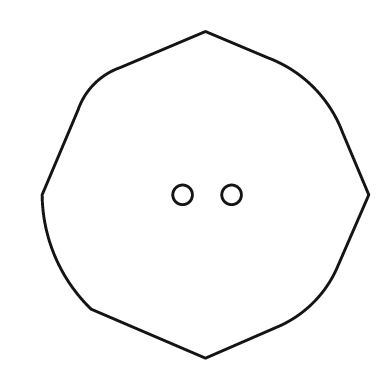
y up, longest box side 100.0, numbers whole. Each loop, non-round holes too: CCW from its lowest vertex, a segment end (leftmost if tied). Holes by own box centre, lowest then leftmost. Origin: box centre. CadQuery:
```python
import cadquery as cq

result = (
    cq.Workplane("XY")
    .moveTo(0.0, -50.0)
    .lineTo(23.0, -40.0)
    .threePointArc((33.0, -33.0), (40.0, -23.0))
    .lineTo(50.0, 0.0)
    .lineTo(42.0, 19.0)
    .threePointArc((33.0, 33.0), (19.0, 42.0))
    .lineTo(0.0, 50.0)
    .lineTo(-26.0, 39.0)
    .threePointArc((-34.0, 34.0), (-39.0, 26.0))
    .lineTo(-50.0, 0.0)
    .threePointArc((-46.0, -19.0), (-35.0, -35.0))
    .close()
    .moveTo(-7.0, 0.0)
    .circle(3.0)
    .moveTo(8.0, 0.0)
    .circle(3.0)
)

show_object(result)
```